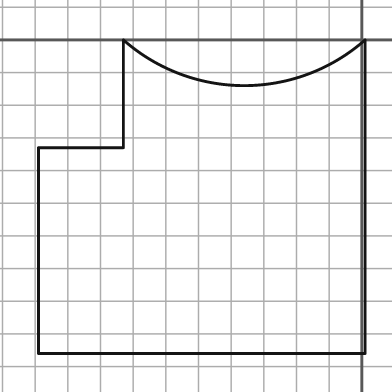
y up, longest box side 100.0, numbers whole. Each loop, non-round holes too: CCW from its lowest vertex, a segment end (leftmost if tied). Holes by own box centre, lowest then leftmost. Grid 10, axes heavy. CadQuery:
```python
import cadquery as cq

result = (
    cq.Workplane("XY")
    .moveTo(-99.0, -96.0)
    .lineTo(1.0, -96.0)
    .lineTo(1.0, 0.0)
    .threePointArc((-36.0, -14.0), (-73.0, 0.0))
    .lineTo(-73.0, -33.0)
    .lineTo(-99.0, -33.0)
    .close()
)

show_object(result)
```